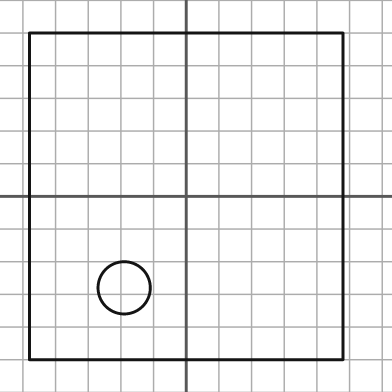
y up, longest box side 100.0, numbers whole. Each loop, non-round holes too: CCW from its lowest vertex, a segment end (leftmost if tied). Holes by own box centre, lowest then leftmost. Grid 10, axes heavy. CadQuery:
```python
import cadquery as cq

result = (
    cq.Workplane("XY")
    .moveTo(-48.0, -50.0)
    .lineTo(48.0, -50.0)
    .lineTo(48.0, 50.0)
    .lineTo(-48.0, 50.0)
    .close()
    .moveTo(-19.0, -28.0)
    .circle(8.0)
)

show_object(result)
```